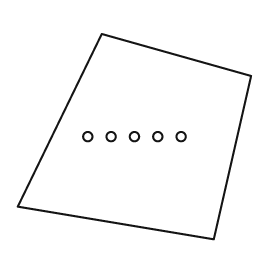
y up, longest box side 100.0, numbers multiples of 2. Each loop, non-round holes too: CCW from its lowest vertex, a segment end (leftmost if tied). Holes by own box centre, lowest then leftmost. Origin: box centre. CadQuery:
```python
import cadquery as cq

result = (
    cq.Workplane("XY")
    .moveTo(34.0, -44.0)
    .lineTo(50.0, 26.0)
    .lineTo(-14.0, 44.0)
    .lineTo(-50.0, -30.0)
    .close()
    .moveTo(-20.0, 0.0)
    .circle(2.0)
    .moveTo(-10.0, 0.0)
    .circle(2.0)
    .moveTo(0.0, 0.0)
    .circle(2.0)
    .moveTo(10.0, 0.0)
    .circle(2.0)
    .moveTo(20.0, 0.0)
    .circle(2.0)
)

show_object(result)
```